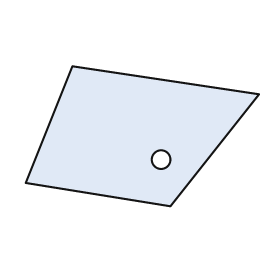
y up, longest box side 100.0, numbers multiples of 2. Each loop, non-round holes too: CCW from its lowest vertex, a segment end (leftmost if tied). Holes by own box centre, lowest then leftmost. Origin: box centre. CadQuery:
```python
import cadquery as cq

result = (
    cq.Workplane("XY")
    .moveTo(12.0, -30.0)
    .lineTo(50.0, 18.0)
    .lineTo(-30.0, 30.0)
    .lineTo(-50.0, -20.0)
    .close()
    .moveTo(8.0, -10.0)
    .circle(4.0)
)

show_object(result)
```